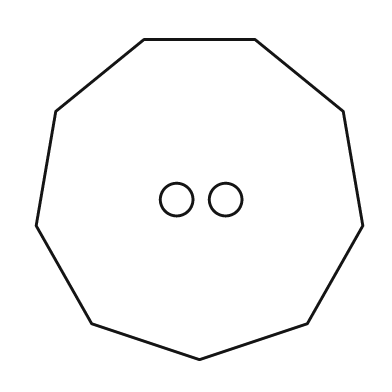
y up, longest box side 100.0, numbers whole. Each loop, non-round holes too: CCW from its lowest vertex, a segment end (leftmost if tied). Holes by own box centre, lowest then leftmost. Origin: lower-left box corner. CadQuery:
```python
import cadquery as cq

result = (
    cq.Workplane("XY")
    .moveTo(50.0, 0.0)
    .lineTo(83.0, 11.0)
    .lineTo(100.0, 41.0)
    .lineTo(94.0, 76.0)
    .lineTo(67.0, 98.0)
    .lineTo(33.0, 98.0)
    .lineTo(6.0, 76.0)
    .lineTo(0.0, 41.0)
    .lineTo(17.0, 11.0)
    .close()
    .moveTo(43.0, 49.0)
    .circle(5.0)
    .moveTo(58.0, 49.0)
    .circle(5.0)
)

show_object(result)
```